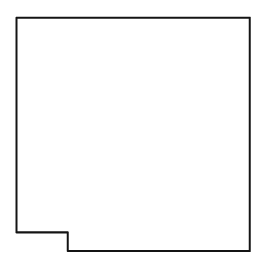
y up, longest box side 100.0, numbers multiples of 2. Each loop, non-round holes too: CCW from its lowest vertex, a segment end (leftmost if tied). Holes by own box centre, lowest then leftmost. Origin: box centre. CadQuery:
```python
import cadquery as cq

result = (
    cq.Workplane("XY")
    .moveTo(-28.0, -50.0)
    .lineTo(50.0, -50.0)
    .lineTo(50.0, 50.0)
    .lineTo(-50.0, 50.0)
    .lineTo(-50.0, -42.0)
    .lineTo(-28.0, -42.0)
    .close()
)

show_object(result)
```